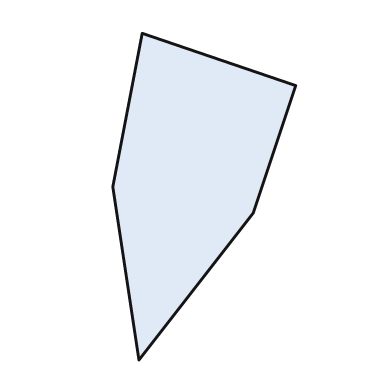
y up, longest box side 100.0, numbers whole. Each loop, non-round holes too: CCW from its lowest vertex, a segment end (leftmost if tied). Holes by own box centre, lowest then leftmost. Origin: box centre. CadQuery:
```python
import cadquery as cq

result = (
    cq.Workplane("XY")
    .moveTo(-20.0, -50.0)
    .lineTo(15.0, -5.0)
    .lineTo(28.0, 34.0)
    .lineTo(-19.0, 50.0)
    .lineTo(-28.0, 3.0)
    .close()
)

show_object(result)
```